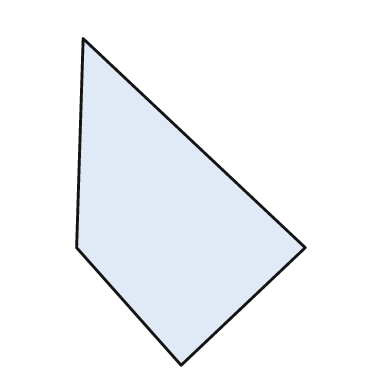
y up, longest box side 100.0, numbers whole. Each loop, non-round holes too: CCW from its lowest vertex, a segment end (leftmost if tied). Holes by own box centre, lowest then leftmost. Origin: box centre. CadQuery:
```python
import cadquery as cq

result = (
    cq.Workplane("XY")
    .moveTo(-3.0, -50.0)
    .lineTo(35.0, -14.0)
    .lineTo(-33.0, 50.0)
    .lineTo(-35.0, -14.0)
    .close()
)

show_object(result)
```